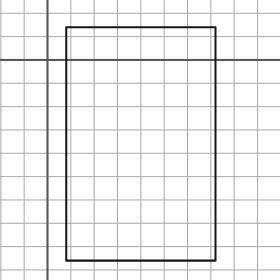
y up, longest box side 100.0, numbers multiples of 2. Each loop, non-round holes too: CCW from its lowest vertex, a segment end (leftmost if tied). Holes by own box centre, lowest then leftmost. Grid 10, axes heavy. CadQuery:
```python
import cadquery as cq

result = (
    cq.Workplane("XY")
    .moveTo(8.0, -86.0)
    .lineTo(72.0, -86.0)
    .lineTo(72.0, 14.0)
    .lineTo(8.0, 14.0)
    .close()
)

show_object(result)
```